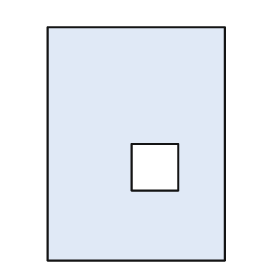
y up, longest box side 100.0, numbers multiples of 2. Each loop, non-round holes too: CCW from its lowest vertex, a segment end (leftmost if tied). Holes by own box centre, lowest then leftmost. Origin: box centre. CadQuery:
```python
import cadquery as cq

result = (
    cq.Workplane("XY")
    .moveTo(-38.0, -50.0)
    .lineTo(38.0, -50.0)
    .lineTo(38.0, 50.0)
    .lineTo(-38.0, 50.0)
    .close()
    .moveTo(-2.0, -20.0)
    .lineTo(18.0, -20.0)
    .lineTo(18.0, 0.0)
    .lineTo(-2.0, 0.0)
    .close()
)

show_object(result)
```